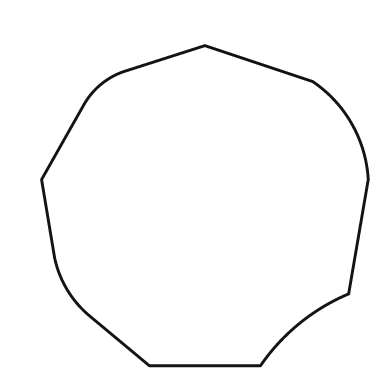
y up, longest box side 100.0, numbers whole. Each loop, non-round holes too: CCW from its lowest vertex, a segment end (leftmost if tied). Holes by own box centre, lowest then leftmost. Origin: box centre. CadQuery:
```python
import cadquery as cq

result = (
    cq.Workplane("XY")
    .moveTo(-17.0, -49.0)
    .lineTo(17.0, -49.0)
    .threePointArc((29.0, -36.0), (44.0, -27.0))
    .lineTo(50.0, 8.0)
    .threePointArc((45.0, 25.0), (33.0, 38.0))
    .lineTo(0.0, 49.0)
    .lineTo(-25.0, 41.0)
    .threePointArc((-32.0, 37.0), (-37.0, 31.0))
    .lineTo(-50.0, 8.0)
    .lineTo(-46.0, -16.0)
    .threePointArc((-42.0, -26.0), (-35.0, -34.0))
    .close()
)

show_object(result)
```